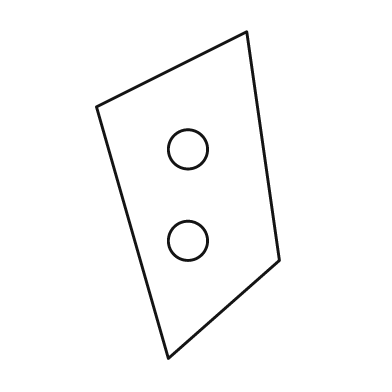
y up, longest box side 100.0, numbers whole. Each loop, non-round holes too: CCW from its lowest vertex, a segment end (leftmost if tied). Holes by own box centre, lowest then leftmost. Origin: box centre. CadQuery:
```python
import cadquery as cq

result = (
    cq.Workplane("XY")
    .moveTo(-6.0, -50.0)
    .lineTo(28.0, -20.0)
    .lineTo(18.0, 50.0)
    .lineTo(-28.0, 27.0)
    .close()
    .moveTo(0.0, -14.0)
    .circle(6.0)
    .moveTo(0.0, 14.0)
    .circle(6.0)
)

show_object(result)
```